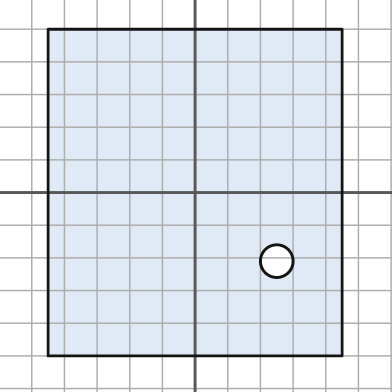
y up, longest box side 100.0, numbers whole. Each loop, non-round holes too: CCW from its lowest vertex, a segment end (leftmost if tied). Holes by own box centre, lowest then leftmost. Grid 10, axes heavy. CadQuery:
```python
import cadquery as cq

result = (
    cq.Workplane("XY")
    .moveTo(-45.0, -50.0)
    .lineTo(45.0, -50.0)
    .lineTo(45.0, 50.0)
    .lineTo(-45.0, 50.0)
    .close()
    .moveTo(25.0, -21.0)
    .circle(5.0)
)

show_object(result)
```